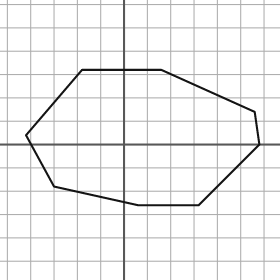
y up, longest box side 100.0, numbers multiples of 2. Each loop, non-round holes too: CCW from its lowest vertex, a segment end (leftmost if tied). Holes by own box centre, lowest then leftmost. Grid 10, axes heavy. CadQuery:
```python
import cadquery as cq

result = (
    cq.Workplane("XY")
    .moveTo(6.0, -26.0)
    .lineTo(32.0, -26.0)
    .lineTo(58.0, 0.0)
    .lineTo(56.0, 14.0)
    .lineTo(16.0, 32.0)
    .lineTo(-18.0, 32.0)
    .lineTo(-42.0, 4.0)
    .lineTo(-30.0, -18.0)
    .close()
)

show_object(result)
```